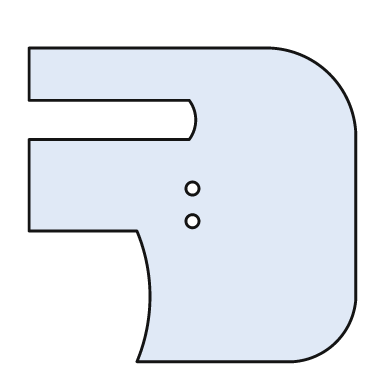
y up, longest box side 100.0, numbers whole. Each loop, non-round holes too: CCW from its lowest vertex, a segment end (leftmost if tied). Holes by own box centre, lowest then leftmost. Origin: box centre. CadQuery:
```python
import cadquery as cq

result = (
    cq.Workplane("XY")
    .moveTo(-17.0, -48.0)
    .lineTo(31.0, -48.0)
    .threePointArc((44.0, -42.0), (50.0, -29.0))
    .lineTo(50.0, 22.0)
    .threePointArc((42.0, 40.0), (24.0, 48.0))
    .lineTo(-50.0, 48.0)
    .lineTo(-50.0, 32.0)
    .lineTo(-1.0, 32.0)
    .threePointArc((1.0, 26.0), (-1.0, 20.0))
    .lineTo(-50.0, 20.0)
    .lineTo(-50.0, -8.0)
    .lineTo(-17.0, -8.0)
    .threePointArc((-13.0, -28.0), (-17.0, -48.0))
    .close()
    .moveTo(0.0, -5.0)
    .circle(2.0)
    .moveTo(0.0, 5.0)
    .circle(2.0)
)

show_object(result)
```